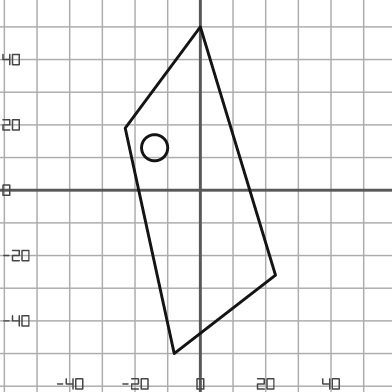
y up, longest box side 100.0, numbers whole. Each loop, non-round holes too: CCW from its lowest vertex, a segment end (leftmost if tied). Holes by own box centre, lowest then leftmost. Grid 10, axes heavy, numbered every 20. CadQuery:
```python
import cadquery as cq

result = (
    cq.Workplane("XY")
    .moveTo(-8.0, -50.0)
    .lineTo(23.0, -26.0)
    .lineTo(0.0, 50.0)
    .lineTo(-23.0, 19.0)
    .close()
    .moveTo(-14.0, 13.0)
    .circle(4.0)
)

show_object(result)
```